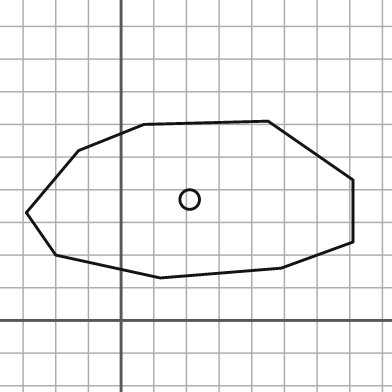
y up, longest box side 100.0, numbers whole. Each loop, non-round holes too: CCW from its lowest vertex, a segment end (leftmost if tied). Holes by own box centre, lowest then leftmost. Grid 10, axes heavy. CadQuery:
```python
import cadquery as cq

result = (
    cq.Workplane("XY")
    .moveTo(12.0, 13.0)
    .lineTo(49.0, 16.0)
    .lineTo(71.0, 24.0)
    .lineTo(71.0, 43.0)
    .lineTo(45.0, 61.0)
    .lineTo(7.0, 60.0)
    .lineTo(-13.0, 52.0)
    .lineTo(-29.0, 33.0)
    .lineTo(-20.0, 20.0)
    .close()
    .moveTo(21.0, 37.0)
    .circle(3.0)
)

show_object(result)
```